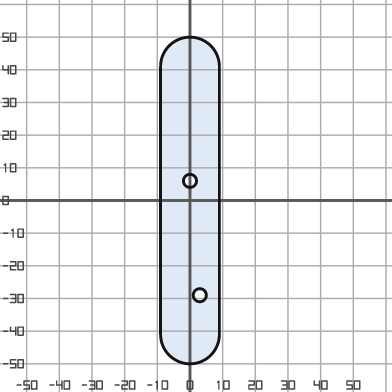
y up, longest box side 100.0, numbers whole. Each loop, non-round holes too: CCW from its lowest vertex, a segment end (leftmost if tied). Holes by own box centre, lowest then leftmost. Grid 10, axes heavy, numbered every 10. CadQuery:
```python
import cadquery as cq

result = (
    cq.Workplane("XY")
    .moveTo(-9.0, -41.0)
    .threePointArc((0.0, -50.0), (9.0, -41.0))
    .lineTo(9.0, 41.0)
    .threePointArc((0.0, 50.0), (-9.0, 41.0))
    .close()
    .moveTo(3.0, -29.0)
    .circle(2.0)
    .moveTo(0.0, 6.0)
    .circle(2.0)
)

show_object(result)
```